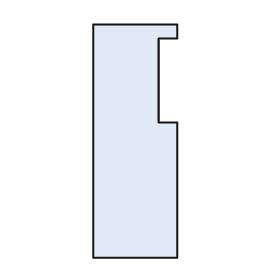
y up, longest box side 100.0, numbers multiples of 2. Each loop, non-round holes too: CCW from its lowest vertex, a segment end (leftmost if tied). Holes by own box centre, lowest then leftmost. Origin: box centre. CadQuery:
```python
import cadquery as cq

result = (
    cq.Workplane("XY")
    .moveTo(-18.0, -50.0)
    .lineTo(18.0, -50.0)
    .lineTo(18.0, 8.0)
    .lineTo(10.0, 8.0)
    .lineTo(10.0, 44.0)
    .lineTo(18.0, 44.0)
    .lineTo(18.0, 50.0)
    .lineTo(-18.0, 50.0)
    .close()
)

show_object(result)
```